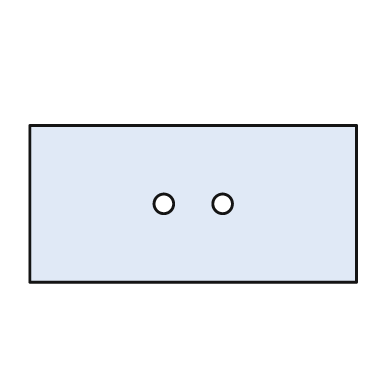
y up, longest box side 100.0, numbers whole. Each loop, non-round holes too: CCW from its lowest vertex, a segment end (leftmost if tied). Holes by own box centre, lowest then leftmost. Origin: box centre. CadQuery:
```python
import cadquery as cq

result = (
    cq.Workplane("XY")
    .moveTo(-50.0, -24.0)
    .lineTo(50.0, -24.0)
    .lineTo(50.0, 24.0)
    .lineTo(-50.0, 24.0)
    .close()
    .moveTo(-9.0, 0.0)
    .circle(3.0)
    .moveTo(9.0, 0.0)
    .circle(3.0)
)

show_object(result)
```